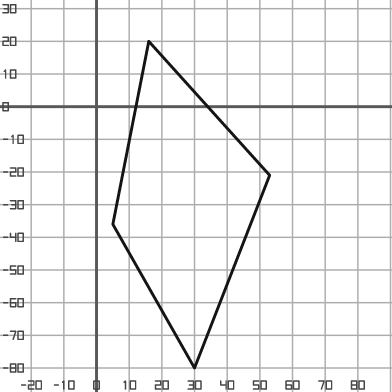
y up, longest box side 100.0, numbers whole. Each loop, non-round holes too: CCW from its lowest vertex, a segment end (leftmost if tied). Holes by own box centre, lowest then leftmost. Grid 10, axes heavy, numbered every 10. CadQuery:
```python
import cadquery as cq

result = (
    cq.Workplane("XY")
    .moveTo(30.0, -80.0)
    .lineTo(53.0, -21.0)
    .lineTo(16.0, 20.0)
    .lineTo(5.0, -36.0)
    .close()
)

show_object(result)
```